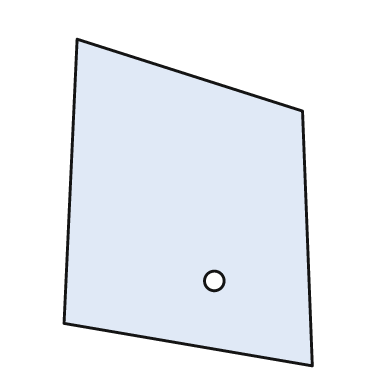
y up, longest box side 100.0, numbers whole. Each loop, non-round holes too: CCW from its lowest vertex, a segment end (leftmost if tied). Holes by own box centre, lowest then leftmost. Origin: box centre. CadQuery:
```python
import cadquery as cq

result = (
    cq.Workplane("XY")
    .moveTo(38.0, -50.0)
    .lineTo(35.0, 28.0)
    .lineTo(-34.0, 50.0)
    .lineTo(-38.0, -37.0)
    .close()
    .moveTo(8.0, -24.0)
    .circle(3.0)
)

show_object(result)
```